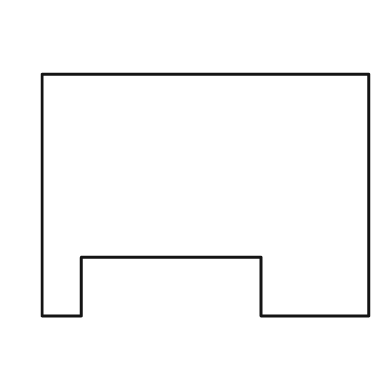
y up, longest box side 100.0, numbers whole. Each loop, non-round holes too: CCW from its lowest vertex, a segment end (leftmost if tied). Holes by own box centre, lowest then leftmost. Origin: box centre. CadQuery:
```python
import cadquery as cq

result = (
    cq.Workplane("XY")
    .moveTo(-50.0, -37.0)
    .lineTo(-38.0, -37.0)
    .lineTo(-38.0, -19.0)
    .lineTo(17.0, -19.0)
    .lineTo(17.0, -37.0)
    .lineTo(50.0, -37.0)
    .lineTo(50.0, 37.0)
    .lineTo(-50.0, 37.0)
    .close()
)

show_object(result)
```